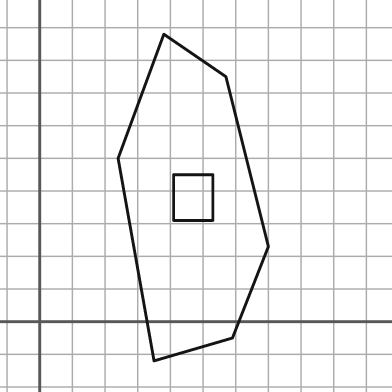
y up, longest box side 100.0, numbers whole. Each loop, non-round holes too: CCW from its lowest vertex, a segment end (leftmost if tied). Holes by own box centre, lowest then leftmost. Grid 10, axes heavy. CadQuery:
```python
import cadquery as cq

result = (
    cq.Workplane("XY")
    .moveTo(35.0, -12.0)
    .lineTo(59.0, -5.0)
    .lineTo(70.0, 23.0)
    .lineTo(57.0, 75.0)
    .lineTo(38.0, 88.0)
    .lineTo(24.0, 50.0)
    .close()
    .moveTo(41.0, 31.0)
    .lineTo(53.0, 31.0)
    .lineTo(53.0, 45.0)
    .lineTo(41.0, 45.0)
    .close()
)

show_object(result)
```